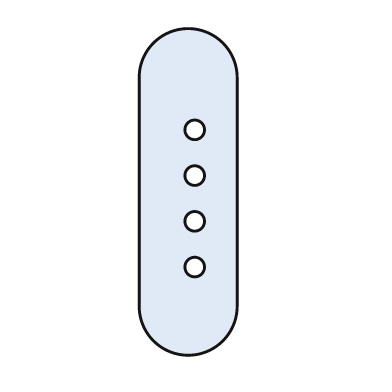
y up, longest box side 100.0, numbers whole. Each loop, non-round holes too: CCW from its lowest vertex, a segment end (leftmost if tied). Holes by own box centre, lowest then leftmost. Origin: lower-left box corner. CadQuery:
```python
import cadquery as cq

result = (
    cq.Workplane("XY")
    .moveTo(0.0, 15.0)
    .threePointArc((15.0, 0.0), (30.0, 15.0))
    .lineTo(30.0, 85.0)
    .threePointArc((15.0, 100.0), (0.0, 85.0))
    .close()
    .moveTo(17.0, 27.0)
    .circle(3.0)
    .moveTo(17.0, 41.0)
    .circle(3.0)
    .moveTo(17.0, 55.0)
    .circle(3.0)
    .moveTo(17.0, 69.0)
    .circle(3.0)
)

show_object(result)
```